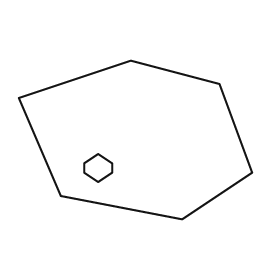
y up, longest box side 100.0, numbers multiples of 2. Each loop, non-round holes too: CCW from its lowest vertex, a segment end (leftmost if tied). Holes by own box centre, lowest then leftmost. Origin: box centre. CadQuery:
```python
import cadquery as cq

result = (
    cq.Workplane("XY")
    .moveTo(20.0, -34.0)
    .lineTo(50.0, -14.0)
    .lineTo(36.0, 24.0)
    .lineTo(-2.0, 34.0)
    .lineTo(-50.0, 18.0)
    .lineTo(-32.0, -24.0)
    .close()
    .moveTo(-16.0, -18.0)
    .lineTo(-10.0, -14.0)
    .lineTo(-10.0, -10.0)
    .lineTo(-16.0, -6.0)
    .lineTo(-22.0, -10.0)
    .lineTo(-22.0, -14.0)
    .close()
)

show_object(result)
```